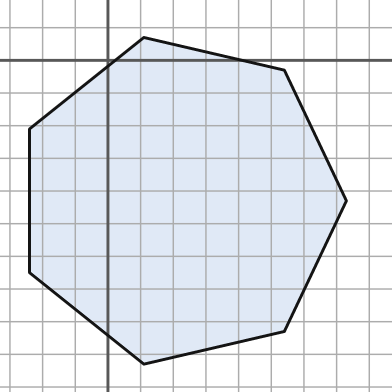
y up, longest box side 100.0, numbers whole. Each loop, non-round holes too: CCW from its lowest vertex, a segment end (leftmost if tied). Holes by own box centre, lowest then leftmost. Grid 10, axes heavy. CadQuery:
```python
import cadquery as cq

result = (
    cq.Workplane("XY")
    .moveTo(11.0, -93.0)
    .lineTo(54.0, -83.0)
    .lineTo(73.0, -43.0)
    .lineTo(54.0, -3.0)
    .lineTo(11.0, 7.0)
    .lineTo(-24.0, -21.0)
    .lineTo(-24.0, -65.0)
    .close()
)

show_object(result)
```